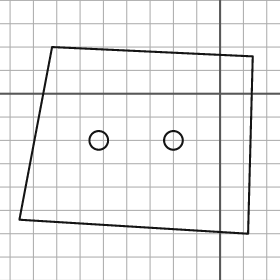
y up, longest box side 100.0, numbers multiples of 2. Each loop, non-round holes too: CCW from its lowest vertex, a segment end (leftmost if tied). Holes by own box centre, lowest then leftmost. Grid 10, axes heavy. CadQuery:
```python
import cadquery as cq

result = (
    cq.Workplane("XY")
    .moveTo(12.0, -60.0)
    .lineTo(14.0, 16.0)
    .lineTo(-72.0, 20.0)
    .lineTo(-86.0, -54.0)
    .close()
    .moveTo(-52.0, -20.0)
    .circle(4.0)
    .moveTo(-20.0, -20.0)
    .circle(4.0)
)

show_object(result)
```